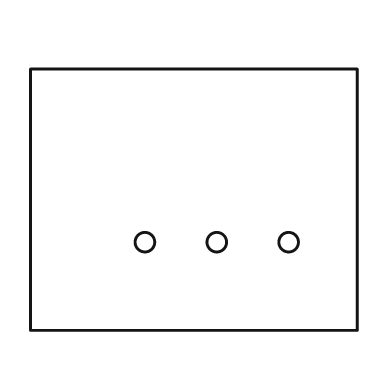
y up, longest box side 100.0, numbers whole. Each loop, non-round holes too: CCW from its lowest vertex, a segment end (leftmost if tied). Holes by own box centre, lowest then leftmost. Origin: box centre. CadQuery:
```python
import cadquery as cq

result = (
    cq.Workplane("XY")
    .moveTo(-50.0, -40.0)
    .lineTo(50.0, -40.0)
    .lineTo(50.0, 40.0)
    .lineTo(-50.0, 40.0)
    .close()
    .moveTo(-15.0, -13.0)
    .circle(3.0)
    .moveTo(7.0, -13.0)
    .circle(3.0)
    .moveTo(29.0, -13.0)
    .circle(3.0)
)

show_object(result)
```